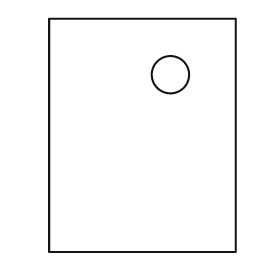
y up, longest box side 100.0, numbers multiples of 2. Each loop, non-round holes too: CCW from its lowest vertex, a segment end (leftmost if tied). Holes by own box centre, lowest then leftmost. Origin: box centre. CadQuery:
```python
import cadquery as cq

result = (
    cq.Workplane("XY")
    .moveTo(-40.0, -50.0)
    .lineTo(40.0, -50.0)
    .lineTo(40.0, 50.0)
    .lineTo(-40.0, 50.0)
    .close()
    .moveTo(12.0, 26.0)
    .circle(8.0)
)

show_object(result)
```